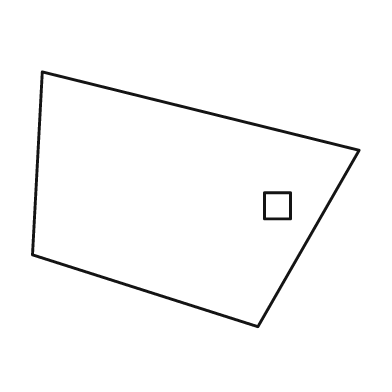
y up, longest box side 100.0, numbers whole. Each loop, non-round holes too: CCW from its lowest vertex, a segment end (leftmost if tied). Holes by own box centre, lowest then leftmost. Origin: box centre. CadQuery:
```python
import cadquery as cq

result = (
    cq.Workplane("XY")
    .moveTo(19.0, -39.0)
    .lineTo(50.0, 15.0)
    .lineTo(-47.0, 39.0)
    .lineTo(-50.0, -17.0)
    .close()
    .moveTo(21.0, -6.0)
    .lineTo(29.0, -6.0)
    .lineTo(29.0, 2.0)
    .lineTo(21.0, 2.0)
    .close()
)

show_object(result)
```